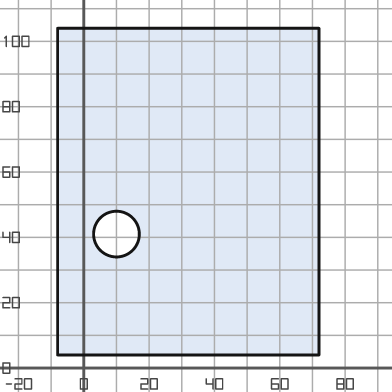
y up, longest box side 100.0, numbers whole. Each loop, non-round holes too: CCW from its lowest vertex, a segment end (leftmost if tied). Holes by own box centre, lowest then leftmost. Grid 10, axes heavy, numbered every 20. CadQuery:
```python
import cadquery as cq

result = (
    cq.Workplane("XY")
    .moveTo(-8.0, 4.0)
    .lineTo(72.0, 4.0)
    .lineTo(72.0, 104.0)
    .lineTo(-8.0, 104.0)
    .close()
    .moveTo(10.0, 41.0)
    .circle(7.0)
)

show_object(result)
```